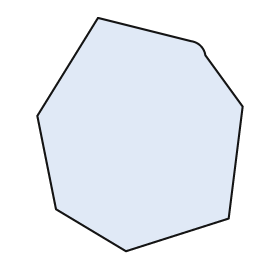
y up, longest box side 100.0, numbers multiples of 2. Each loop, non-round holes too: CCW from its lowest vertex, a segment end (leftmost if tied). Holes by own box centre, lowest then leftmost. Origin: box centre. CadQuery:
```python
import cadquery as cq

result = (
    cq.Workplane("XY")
    .moveTo(-6.0, -50.0)
    .lineTo(38.0, -36.0)
    .lineTo(44.0, 12.0)
    .lineTo(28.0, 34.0)
    .threePointArc((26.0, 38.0), (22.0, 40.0))
    .lineTo(-18.0, 50.0)
    .lineTo(-44.0, 8.0)
    .lineTo(-36.0, -32.0)
    .close()
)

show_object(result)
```